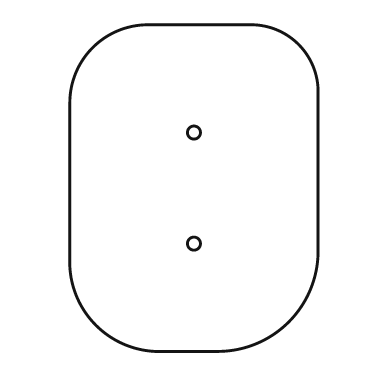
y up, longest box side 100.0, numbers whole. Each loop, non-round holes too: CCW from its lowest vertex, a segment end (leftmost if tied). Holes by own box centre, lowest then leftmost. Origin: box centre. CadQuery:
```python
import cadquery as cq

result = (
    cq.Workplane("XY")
    .moveTo(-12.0, -50.0)
    .lineTo(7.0, -50.0)
    .threePointArc((29.0, -41.0), (38.0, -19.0))
    .lineTo(38.0, 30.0)
    .threePointArc((32.0, 44.0), (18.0, 50.0))
    .lineTo(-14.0, 50.0)
    .threePointArc((-31.0, 43.0), (-38.0, 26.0))
    .lineTo(-38.0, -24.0)
    .threePointArc((-30.0, -42.0), (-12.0, -50.0))
    .close()
    .moveTo(0.0, -17.0)
    .circle(2.0)
    .moveTo(0.0, 17.0)
    .circle(2.0)
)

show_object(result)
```